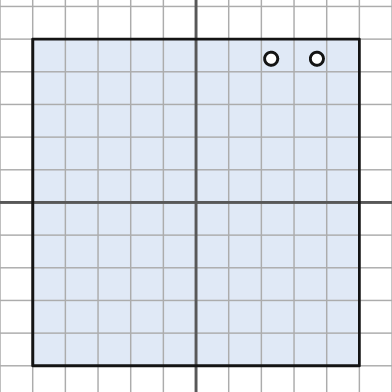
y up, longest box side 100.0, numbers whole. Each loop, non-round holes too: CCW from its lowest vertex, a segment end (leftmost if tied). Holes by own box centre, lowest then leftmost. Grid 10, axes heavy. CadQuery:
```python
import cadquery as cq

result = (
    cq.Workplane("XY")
    .moveTo(-50.0, -50.0)
    .lineTo(50.0, -50.0)
    .lineTo(50.0, 50.0)
    .lineTo(-50.0, 50.0)
    .close()
    .moveTo(23.0, 44.0)
    .circle(2.0)
    .moveTo(37.0, 44.0)
    .circle(2.0)
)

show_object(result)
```